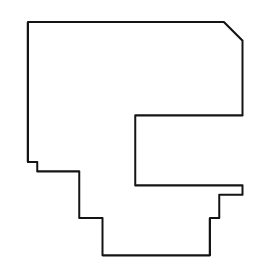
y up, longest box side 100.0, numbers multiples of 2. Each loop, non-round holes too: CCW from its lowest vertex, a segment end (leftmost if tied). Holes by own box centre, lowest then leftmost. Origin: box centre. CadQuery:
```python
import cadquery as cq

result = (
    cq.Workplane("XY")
    .moveTo(-14.0, -50.0)
    .lineTo(32.0, -50.0)
    .lineTo(32.0, -34.0)
    .lineTo(36.0, -34.0)
    .lineTo(36.0, -24.0)
    .lineTo(46.0, -24.0)
    .lineTo(46.0, -20.0)
    .lineTo(0.0, -20.0)
    .lineTo(0.0, 10.0)
    .lineTo(46.0, 10.0)
    .lineTo(46.0, 42.0)
    .lineTo(38.0, 50.0)
    .lineTo(-46.0, 50.0)
    .lineTo(-46.0, -10.0)
    .lineTo(-42.0, -10.0)
    .lineTo(-42.0, -14.0)
    .lineTo(-24.0, -14.0)
    .lineTo(-24.0, -34.0)
    .lineTo(-14.0, -34.0)
    .close()
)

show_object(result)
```